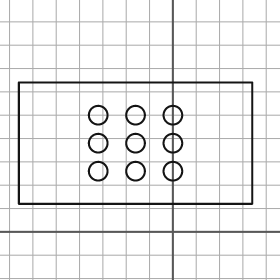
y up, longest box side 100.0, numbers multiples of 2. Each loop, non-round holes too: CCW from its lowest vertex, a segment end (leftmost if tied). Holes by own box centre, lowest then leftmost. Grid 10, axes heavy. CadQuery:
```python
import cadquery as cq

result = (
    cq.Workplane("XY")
    .moveTo(-66.0, 12.0)
    .lineTo(34.0, 12.0)
    .lineTo(34.0, 64.0)
    .lineTo(-66.0, 64.0)
    .close()
    .moveTo(-32.0, 26.0)
    .circle(4.0)
    .moveTo(-16.0, 26.0)
    .circle(4.0)
    .moveTo(0.0, 26.0)
    .circle(4.0)
    .moveTo(-32.0, 38.0)
    .circle(4.0)
    .moveTo(-16.0, 38.0)
    .circle(4.0)
    .moveTo(0.0, 38.0)
    .circle(4.0)
    .moveTo(-32.0, 50.0)
    .circle(4.0)
    .moveTo(-16.0, 50.0)
    .circle(4.0)
    .moveTo(0.0, 50.0)
    .circle(4.0)
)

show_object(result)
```